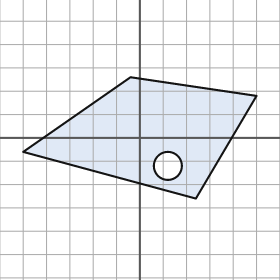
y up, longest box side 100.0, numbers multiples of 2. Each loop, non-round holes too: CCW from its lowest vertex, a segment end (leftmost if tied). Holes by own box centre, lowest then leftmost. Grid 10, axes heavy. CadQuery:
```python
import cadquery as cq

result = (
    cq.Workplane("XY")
    .moveTo(24.0, -26.0)
    .lineTo(50.0, 18.0)
    .lineTo(-4.0, 26.0)
    .lineTo(-50.0, -6.0)
    .close()
    .moveTo(12.0, -12.0)
    .circle(6.0)
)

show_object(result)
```